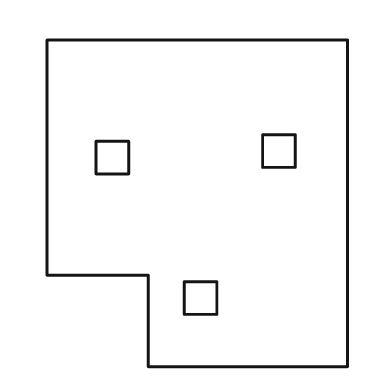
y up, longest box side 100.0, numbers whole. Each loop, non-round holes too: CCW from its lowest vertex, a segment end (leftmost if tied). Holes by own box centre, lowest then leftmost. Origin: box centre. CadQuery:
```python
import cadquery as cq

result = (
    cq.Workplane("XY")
    .moveTo(-15.0, -50.0)
    .lineTo(46.0, -50.0)
    .lineTo(46.0, 50.0)
    .lineTo(-46.0, 50.0)
    .lineTo(-46.0, -22.0)
    .lineTo(-15.0, -22.0)
    .close()
    .moveTo(-4.0, -34.0)
    .lineTo(6.0, -34.0)
    .lineTo(6.0, -24.0)
    .lineTo(-4.0, -24.0)
    .close()
    .moveTo(-31.0, 9.0)
    .lineTo(-21.0, 9.0)
    .lineTo(-21.0, 19.0)
    .lineTo(-31.0, 19.0)
    .close()
    .moveTo(20.0, 11.0)
    .lineTo(30.0, 11.0)
    .lineTo(30.0, 21.0)
    .lineTo(20.0, 21.0)
    .close()
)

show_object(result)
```